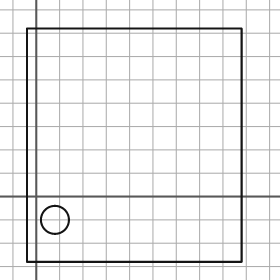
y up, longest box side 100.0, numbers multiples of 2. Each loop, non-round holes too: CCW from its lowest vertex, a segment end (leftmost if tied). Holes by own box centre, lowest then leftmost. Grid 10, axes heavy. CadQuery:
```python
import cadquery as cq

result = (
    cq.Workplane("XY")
    .moveTo(-4.0, -28.0)
    .lineTo(88.0, -28.0)
    .lineTo(88.0, 72.0)
    .lineTo(-4.0, 72.0)
    .close()
    .moveTo(8.0, -10.0)
    .circle(6.0)
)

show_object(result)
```